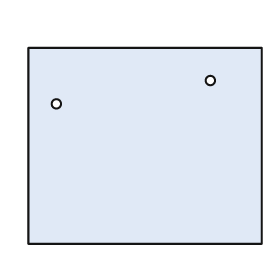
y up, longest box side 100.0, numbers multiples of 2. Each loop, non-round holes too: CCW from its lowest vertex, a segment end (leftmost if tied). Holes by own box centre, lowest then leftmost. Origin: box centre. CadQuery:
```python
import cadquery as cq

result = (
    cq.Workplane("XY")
    .moveTo(-50.0, -42.0)
    .lineTo(50.0, -42.0)
    .lineTo(50.0, 42.0)
    .lineTo(-50.0, 42.0)
    .close()
    .moveTo(-38.0, 18.0)
    .circle(2.0)
    .moveTo(28.0, 28.0)
    .circle(2.0)
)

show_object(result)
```